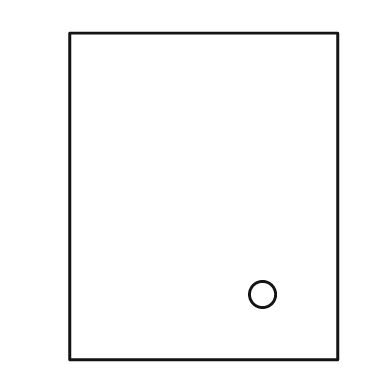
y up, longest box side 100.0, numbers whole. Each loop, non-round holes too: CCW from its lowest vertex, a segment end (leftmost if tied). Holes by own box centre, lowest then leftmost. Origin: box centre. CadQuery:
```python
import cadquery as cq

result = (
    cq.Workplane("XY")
    .moveTo(-41.0, -50.0)
    .lineTo(41.0, -50.0)
    .lineTo(41.0, 50.0)
    .lineTo(-41.0, 50.0)
    .close()
    .moveTo(18.0, -30.0)
    .circle(4.0)
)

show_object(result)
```